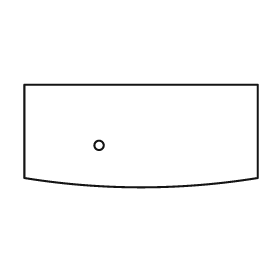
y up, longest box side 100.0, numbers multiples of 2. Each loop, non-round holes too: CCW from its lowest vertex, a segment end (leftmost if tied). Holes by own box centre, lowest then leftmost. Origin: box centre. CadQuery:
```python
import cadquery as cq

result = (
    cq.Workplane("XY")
    .moveTo(-50.0, -18.0)
    .threePointArc((0.0, -22.0), (50.0, -18.0))
    .lineTo(50.0, 22.0)
    .lineTo(-50.0, 22.0)
    .close()
    .moveTo(-18.0, -4.0)
    .circle(2.0)
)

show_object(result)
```